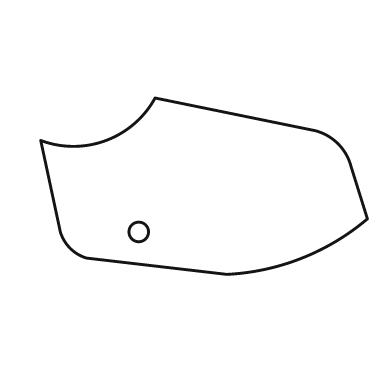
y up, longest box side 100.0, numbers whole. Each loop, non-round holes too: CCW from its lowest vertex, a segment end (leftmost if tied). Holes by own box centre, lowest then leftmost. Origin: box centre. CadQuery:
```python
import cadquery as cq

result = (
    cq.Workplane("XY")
    .moveTo(7.0, -27.0)
    .threePointArc((30.0, -22.0), (50.0, -10.0))
    .lineTo(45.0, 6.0)
    .threePointArc((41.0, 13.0), (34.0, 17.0))
    .lineTo(-15.0, 27.0)
    .threePointArc((-30.0, 14.0), (-50.0, 14.0))
    .lineTo(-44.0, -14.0)
    .threePointArc((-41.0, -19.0), (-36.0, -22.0))
    .close()
    .moveTo(-20.0, -14.0)
    .circle(3.0)
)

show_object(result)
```